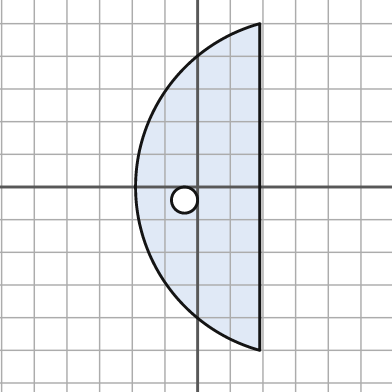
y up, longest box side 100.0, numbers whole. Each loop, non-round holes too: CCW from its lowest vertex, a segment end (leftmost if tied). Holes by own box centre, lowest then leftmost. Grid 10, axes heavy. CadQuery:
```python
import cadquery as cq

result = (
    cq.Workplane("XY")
    .moveTo(19.0, -50.0)
    .lineTo(19.0, 50.0)
    .threePointArc((-19.0, 0.0), (19.0, -50.0))
    .close()
    .moveTo(-4.0, -4.0)
    .circle(4.0)
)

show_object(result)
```